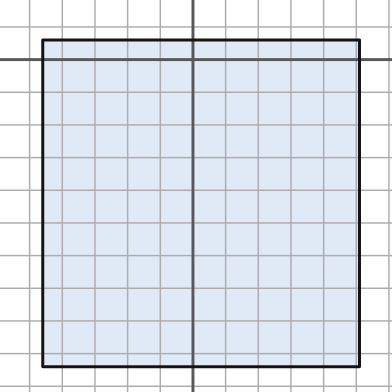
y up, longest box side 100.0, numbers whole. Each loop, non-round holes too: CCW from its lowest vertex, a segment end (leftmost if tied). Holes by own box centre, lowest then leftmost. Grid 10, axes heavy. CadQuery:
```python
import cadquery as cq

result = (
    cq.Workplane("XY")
    .moveTo(-46.0, -94.0)
    .lineTo(51.0, -94.0)
    .lineTo(51.0, 6.0)
    .lineTo(-46.0, 6.0)
    .close()
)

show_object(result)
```